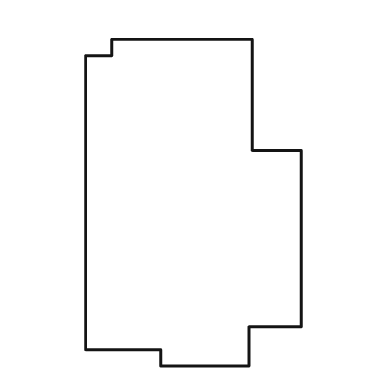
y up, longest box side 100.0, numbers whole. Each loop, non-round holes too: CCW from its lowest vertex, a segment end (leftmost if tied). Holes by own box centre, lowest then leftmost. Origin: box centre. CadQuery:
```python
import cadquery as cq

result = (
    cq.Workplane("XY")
    .moveTo(-10.0, -50.0)
    .lineTo(17.0, -50.0)
    .lineTo(17.0, -38.0)
    .lineTo(33.0, -38.0)
    .lineTo(33.0, 16.0)
    .lineTo(18.0, 16.0)
    .lineTo(18.0, 50.0)
    .lineTo(-25.0, 50.0)
    .lineTo(-25.0, 45.0)
    .lineTo(-33.0, 45.0)
    .lineTo(-33.0, -45.0)
    .lineTo(-10.0, -45.0)
    .close()
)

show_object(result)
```